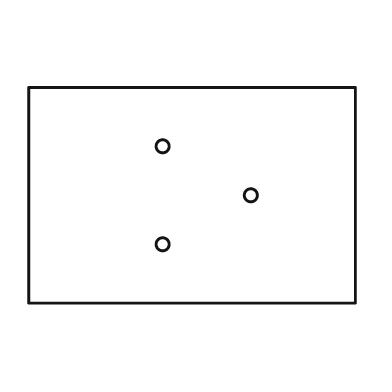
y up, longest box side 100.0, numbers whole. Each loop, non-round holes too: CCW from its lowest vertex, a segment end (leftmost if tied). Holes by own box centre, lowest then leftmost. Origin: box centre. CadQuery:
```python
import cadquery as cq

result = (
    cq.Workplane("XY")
    .moveTo(-50.0, -33.0)
    .lineTo(50.0, -33.0)
    .lineTo(50.0, 33.0)
    .lineTo(-50.0, 33.0)
    .close()
    .moveTo(-9.0, -15.0)
    .circle(2.0)
    .moveTo(18.0, 0.0)
    .circle(2.0)
    .moveTo(-9.0, 15.0)
    .circle(2.0)
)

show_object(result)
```